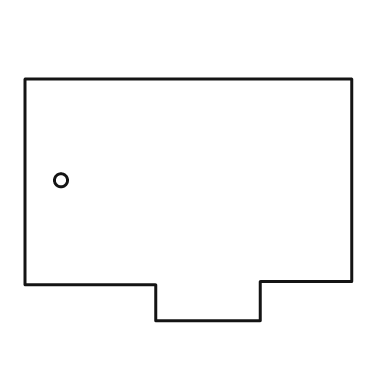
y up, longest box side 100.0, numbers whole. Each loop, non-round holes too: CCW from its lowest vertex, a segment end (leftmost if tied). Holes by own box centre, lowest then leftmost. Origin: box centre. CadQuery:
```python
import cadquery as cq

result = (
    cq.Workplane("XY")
    .moveTo(-10.0, -37.0)
    .lineTo(22.0, -37.0)
    .lineTo(22.0, -25.0)
    .lineTo(50.0, -25.0)
    .lineTo(50.0, 37.0)
    .lineTo(-50.0, 37.0)
    .lineTo(-50.0, -26.0)
    .lineTo(-10.0, -26.0)
    .close()
    .moveTo(-39.0, 6.0)
    .circle(2.0)
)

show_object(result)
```